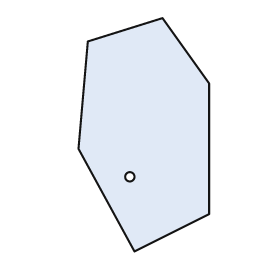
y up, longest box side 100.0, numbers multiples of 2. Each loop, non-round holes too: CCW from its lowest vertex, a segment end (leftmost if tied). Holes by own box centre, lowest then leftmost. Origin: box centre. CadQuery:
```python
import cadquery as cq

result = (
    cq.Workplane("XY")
    .moveTo(-4.0, -50.0)
    .lineTo(28.0, -34.0)
    .lineTo(28.0, 22.0)
    .lineTo(8.0, 50.0)
    .lineTo(-24.0, 40.0)
    .lineTo(-28.0, -6.0)
    .close()
    .moveTo(-6.0, -18.0)
    .circle(2.0)
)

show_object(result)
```